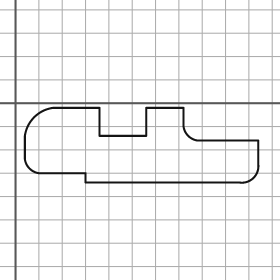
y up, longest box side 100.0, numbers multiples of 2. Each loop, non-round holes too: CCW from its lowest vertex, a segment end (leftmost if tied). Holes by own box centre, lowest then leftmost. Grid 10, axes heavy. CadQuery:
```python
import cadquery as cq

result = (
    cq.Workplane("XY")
    .moveTo(30.0, -34.0)
    .lineTo(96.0, -34.0)
    .threePointArc((102.0, -32.0), (104.0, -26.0))
    .lineTo(104.0, -16.0)
    .lineTo(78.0, -16.0)
    .threePointArc((74.0, -14.0), (72.0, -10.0))
    .lineTo(72.0, -2.0)
    .lineTo(56.0, -2.0)
    .lineTo(56.0, -14.0)
    .lineTo(36.0, -14.0)
    .lineTo(36.0, -2.0)
    .lineTo(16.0, -2.0)
    .threePointArc((8.0, -6.0), (4.0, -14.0))
    .lineTo(4.0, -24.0)
    .threePointArc((6.0, -28.0), (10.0, -30.0))
    .lineTo(30.0, -30.0)
    .close()
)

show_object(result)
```